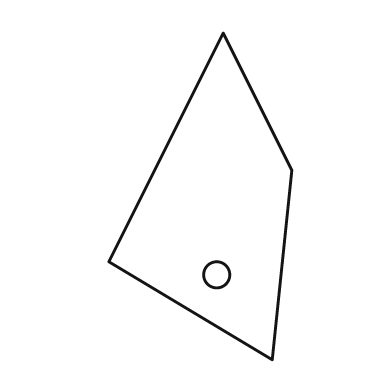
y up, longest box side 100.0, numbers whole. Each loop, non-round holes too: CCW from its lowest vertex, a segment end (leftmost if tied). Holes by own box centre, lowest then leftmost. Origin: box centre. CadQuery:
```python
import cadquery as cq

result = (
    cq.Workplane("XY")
    .moveTo(22.0, -50.0)
    .lineTo(28.0, 8.0)
    .lineTo(7.0, 50.0)
    .lineTo(-28.0, -20.0)
    .close()
    .moveTo(5.0, -24.0)
    .circle(4.0)
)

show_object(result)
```